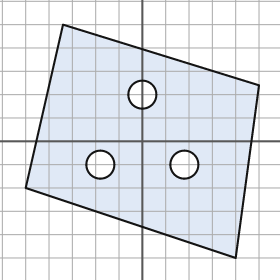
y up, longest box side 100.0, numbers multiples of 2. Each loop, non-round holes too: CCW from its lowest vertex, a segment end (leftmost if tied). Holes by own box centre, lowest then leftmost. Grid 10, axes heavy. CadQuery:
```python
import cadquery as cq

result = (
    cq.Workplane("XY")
    .moveTo(40.0, -50.0)
    .lineTo(50.0, 24.0)
    .lineTo(-34.0, 50.0)
    .lineTo(-50.0, -20.0)
    .close()
    .moveTo(-18.0, -10.0)
    .circle(6.0)
    .moveTo(18.0, -10.0)
    .circle(6.0)
    .moveTo(0.0, 20.0)
    .circle(6.0)
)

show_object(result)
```